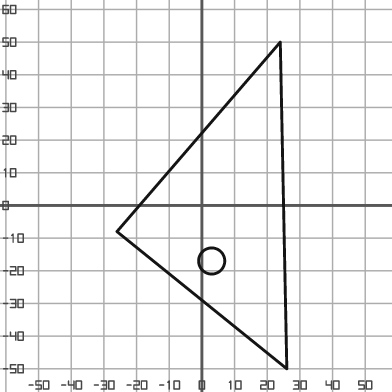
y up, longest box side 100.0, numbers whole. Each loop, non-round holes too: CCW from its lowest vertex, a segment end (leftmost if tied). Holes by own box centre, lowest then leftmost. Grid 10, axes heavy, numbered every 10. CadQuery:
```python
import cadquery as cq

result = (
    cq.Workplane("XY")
    .moveTo(26.0, -50.0)
    .lineTo(24.0, 50.0)
    .lineTo(-26.0, -8.0)
    .close()
    .moveTo(3.0, -17.0)
    .circle(4.0)
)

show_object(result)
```